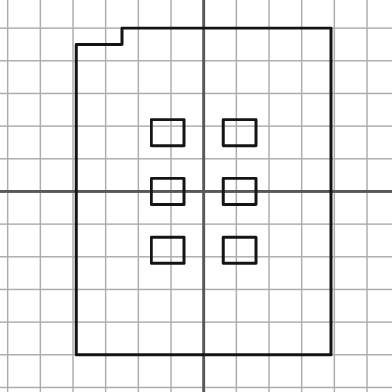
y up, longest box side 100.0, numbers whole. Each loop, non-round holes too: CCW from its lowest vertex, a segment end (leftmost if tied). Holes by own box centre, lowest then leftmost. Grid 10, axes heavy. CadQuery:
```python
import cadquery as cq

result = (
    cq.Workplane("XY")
    .moveTo(-39.0, -50.0)
    .lineTo(39.0, -50.0)
    .lineTo(39.0, 50.0)
    .lineTo(-25.0, 50.0)
    .lineTo(-25.0, 45.0)
    .lineTo(-39.0, 45.0)
    .close()
    .moveTo(-16.0, -22.0)
    .lineTo(-6.0, -22.0)
    .lineTo(-6.0, -14.0)
    .lineTo(-16.0, -14.0)
    .close()
    .moveTo(6.0, -22.0)
    .lineTo(16.0, -22.0)
    .lineTo(16.0, -14.0)
    .lineTo(6.0, -14.0)
    .close()
    .moveTo(-16.0, -4.0)
    .lineTo(-6.0, -4.0)
    .lineTo(-6.0, 4.0)
    .lineTo(-16.0, 4.0)
    .close()
    .moveTo(6.0, -4.0)
    .lineTo(16.0, -4.0)
    .lineTo(16.0, 4.0)
    .lineTo(6.0, 4.0)
    .close()
    .moveTo(-16.0, 14.0)
    .lineTo(-6.0, 14.0)
    .lineTo(-6.0, 22.0)
    .lineTo(-16.0, 22.0)
    .close()
    .moveTo(6.0, 14.0)
    .lineTo(16.0, 14.0)
    .lineTo(16.0, 22.0)
    .lineTo(6.0, 22.0)
    .close()
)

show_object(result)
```